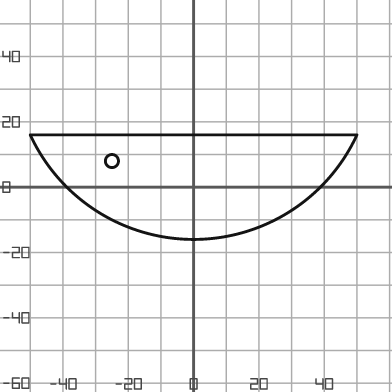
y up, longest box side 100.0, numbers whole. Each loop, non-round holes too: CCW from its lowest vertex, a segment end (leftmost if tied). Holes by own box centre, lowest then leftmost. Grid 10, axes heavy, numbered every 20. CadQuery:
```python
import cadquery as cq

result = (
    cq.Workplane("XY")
    .moveTo(-50.0, 16.0)
    .threePointArc((0.0, -16.0), (50.0, 16.0))
    .close()
    .moveTo(-25.0, 8.0)
    .circle(2.0)
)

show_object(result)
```